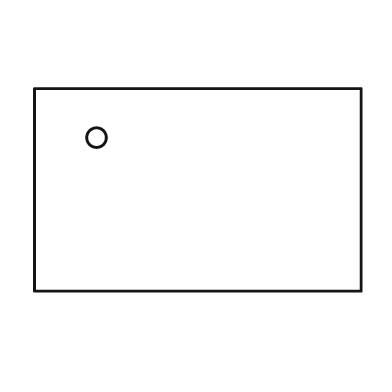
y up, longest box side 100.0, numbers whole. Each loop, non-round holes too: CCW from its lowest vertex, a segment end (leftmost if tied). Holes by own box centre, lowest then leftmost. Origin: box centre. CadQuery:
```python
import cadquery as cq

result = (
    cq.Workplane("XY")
    .moveTo(-50.0, -31.0)
    .lineTo(50.0, -31.0)
    .lineTo(50.0, 31.0)
    .lineTo(-50.0, 31.0)
    .close()
    .moveTo(-31.0, 16.0)
    .circle(3.0)
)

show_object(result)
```